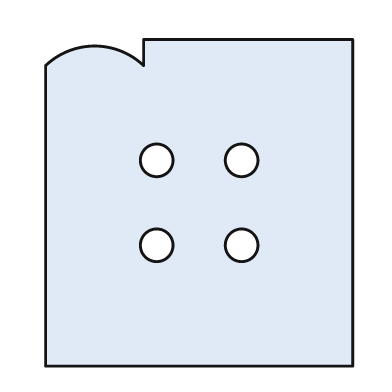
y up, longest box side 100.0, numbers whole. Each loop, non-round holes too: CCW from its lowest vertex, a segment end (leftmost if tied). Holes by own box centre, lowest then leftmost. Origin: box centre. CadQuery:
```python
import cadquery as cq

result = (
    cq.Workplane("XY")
    .moveTo(-47.0, -50.0)
    .lineTo(47.0, -50.0)
    .lineTo(47.0, 50.0)
    .lineTo(-17.0, 50.0)
    .lineTo(-17.0, 42.0)
    .threePointArc((-32.0, 48.0), (-47.0, 42.0))
    .close()
    .moveTo(-13.0, -13.0)
    .circle(5.0)
    .moveTo(13.0, -13.0)
    .circle(5.0)
    .moveTo(-13.0, 13.0)
    .circle(5.0)
    .moveTo(13.0, 13.0)
    .circle(5.0)
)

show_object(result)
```